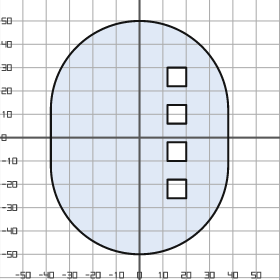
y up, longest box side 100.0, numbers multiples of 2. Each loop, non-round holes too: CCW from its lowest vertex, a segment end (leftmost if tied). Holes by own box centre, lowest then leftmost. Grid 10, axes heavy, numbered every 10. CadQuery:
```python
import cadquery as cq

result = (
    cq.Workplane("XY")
    .moveTo(-38.0, -12.0)
    .threePointArc((0.0, -50.0), (38.0, -12.0))
    .lineTo(38.0, 12.0)
    .threePointArc((0.0, 50.0), (-38.0, 12.0))
    .close()
    .moveTo(12.0, -26.0)
    .lineTo(20.0, -26.0)
    .lineTo(20.0, -18.0)
    .lineTo(12.0, -18.0)
    .close()
    .moveTo(12.0, -10.0)
    .lineTo(20.0, -10.0)
    .lineTo(20.0, -2.0)
    .lineTo(12.0, -2.0)
    .close()
    .moveTo(12.0, 6.0)
    .lineTo(20.0, 6.0)
    .lineTo(20.0, 14.0)
    .lineTo(12.0, 14.0)
    .close()
    .moveTo(12.0, 22.0)
    .lineTo(20.0, 22.0)
    .lineTo(20.0, 30.0)
    .lineTo(12.0, 30.0)
    .close()
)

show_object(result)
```